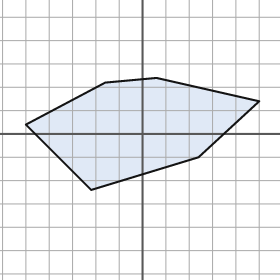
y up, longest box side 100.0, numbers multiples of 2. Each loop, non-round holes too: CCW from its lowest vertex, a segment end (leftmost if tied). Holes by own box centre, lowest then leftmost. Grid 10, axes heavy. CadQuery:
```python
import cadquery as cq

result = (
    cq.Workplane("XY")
    .moveTo(-22.0, -24.0)
    .lineTo(24.0, -10.0)
    .lineTo(50.0, 14.0)
    .lineTo(6.0, 24.0)
    .lineTo(-16.0, 22.0)
    .lineTo(-50.0, 4.0)
    .close()
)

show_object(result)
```